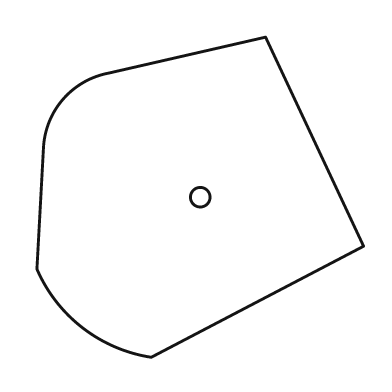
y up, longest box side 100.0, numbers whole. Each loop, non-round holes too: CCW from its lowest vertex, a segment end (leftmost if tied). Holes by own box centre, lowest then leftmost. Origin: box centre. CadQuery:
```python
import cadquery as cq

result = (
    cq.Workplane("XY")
    .moveTo(-15.0, -49.0)
    .lineTo(50.0, -15.0)
    .lineTo(20.0, 49.0)
    .lineTo(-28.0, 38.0)
    .threePointArc((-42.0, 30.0), (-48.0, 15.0))
    .lineTo(-50.0, -22.0)
    .threePointArc((-36.0, -40.0), (-15.0, -49.0))
    .close()
    .moveTo(0.0, 0.0)
    .circle(3.0)
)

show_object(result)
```